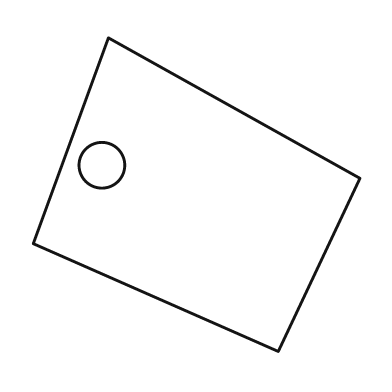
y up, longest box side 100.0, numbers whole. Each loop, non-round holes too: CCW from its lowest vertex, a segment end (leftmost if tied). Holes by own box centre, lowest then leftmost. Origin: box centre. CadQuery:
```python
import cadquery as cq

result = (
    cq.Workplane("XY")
    .moveTo(25.0, -48.0)
    .lineTo(50.0, 5.0)
    .lineTo(-27.0, 48.0)
    .lineTo(-50.0, -15.0)
    .close()
    .moveTo(-29.0, 9.0)
    .circle(7.0)
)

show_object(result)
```